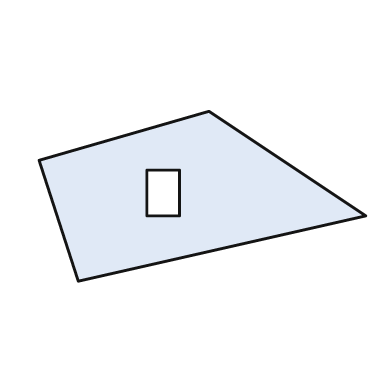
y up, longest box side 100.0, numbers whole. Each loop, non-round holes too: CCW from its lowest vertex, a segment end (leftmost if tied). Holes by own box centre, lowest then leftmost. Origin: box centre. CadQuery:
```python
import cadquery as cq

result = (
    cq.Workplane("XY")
    .moveTo(-38.0, -26.0)
    .lineTo(50.0, -6.0)
    .lineTo(2.0, 26.0)
    .lineTo(-50.0, 11.0)
    .close()
    .moveTo(-17.0, -6.0)
    .lineTo(-7.0, -6.0)
    .lineTo(-7.0, 8.0)
    .lineTo(-17.0, 8.0)
    .close()
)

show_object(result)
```